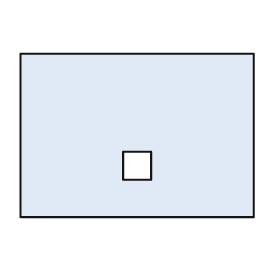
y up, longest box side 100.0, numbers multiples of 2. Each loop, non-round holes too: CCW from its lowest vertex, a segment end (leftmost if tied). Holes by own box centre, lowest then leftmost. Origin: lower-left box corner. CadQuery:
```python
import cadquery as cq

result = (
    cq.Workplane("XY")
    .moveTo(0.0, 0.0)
    .lineTo(100.0, 0.0)
    .lineTo(100.0, 70.0)
    .lineTo(0.0, 70.0)
    .close()
    .moveTo(44.0, 16.0)
    .lineTo(56.0, 16.0)
    .lineTo(56.0, 28.0)
    .lineTo(44.0, 28.0)
    .close()
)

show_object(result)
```